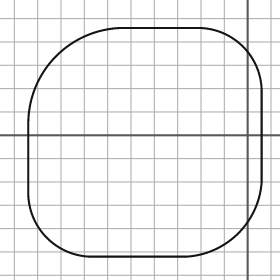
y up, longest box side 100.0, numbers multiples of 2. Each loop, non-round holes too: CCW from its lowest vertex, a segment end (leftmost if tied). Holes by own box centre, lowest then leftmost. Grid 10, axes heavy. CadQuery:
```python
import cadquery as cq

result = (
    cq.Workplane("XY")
    .moveTo(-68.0, -52.0)
    .lineTo(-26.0, -52.0)
    .threePointArc((-4.0, -42.0), (6.0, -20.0))
    .lineTo(6.0, 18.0)
    .threePointArc((-2.0, 38.0), (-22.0, 46.0))
    .lineTo(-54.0, 46.0)
    .threePointArc((-82.0, 34.0), (-94.0, 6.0))
    .lineTo(-94.0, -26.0)
    .threePointArc((-86.0, -44.0), (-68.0, -52.0))
    .close()
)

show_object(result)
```